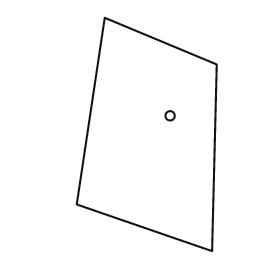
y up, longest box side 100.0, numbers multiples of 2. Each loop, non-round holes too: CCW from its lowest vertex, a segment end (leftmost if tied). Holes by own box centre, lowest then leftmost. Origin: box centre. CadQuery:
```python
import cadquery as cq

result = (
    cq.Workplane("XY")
    .moveTo(28.0, -50.0)
    .lineTo(30.0, 30.0)
    .lineTo(-18.0, 50.0)
    .lineTo(-30.0, -30.0)
    .close()
    .moveTo(10.0, 8.0)
    .circle(2.0)
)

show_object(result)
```